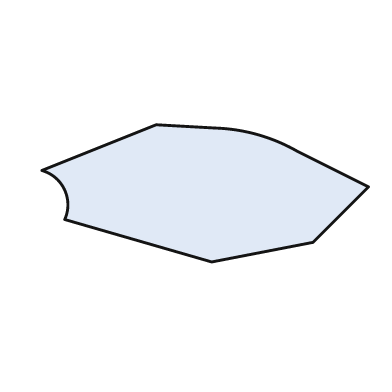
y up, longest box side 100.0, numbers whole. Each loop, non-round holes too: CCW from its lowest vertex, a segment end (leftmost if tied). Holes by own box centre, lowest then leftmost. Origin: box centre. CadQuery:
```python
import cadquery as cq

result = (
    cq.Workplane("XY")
    .moveTo(2.0, -21.0)
    .lineTo(33.0, -15.0)
    .lineTo(50.0, 2.0)
    .lineTo(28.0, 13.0)
    .threePointArc((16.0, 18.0), (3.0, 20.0))
    .lineTo(-15.0, 21.0)
    .lineTo(-50.0, 7.0)
    .threePointArc((-43.0, 1.0), (-43.0, -8.0))
    .close()
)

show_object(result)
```